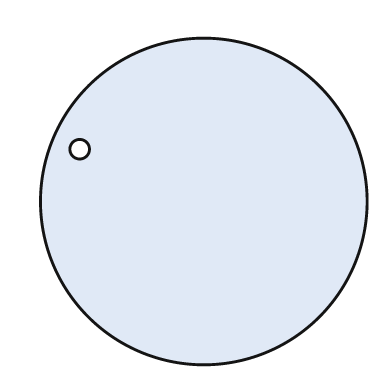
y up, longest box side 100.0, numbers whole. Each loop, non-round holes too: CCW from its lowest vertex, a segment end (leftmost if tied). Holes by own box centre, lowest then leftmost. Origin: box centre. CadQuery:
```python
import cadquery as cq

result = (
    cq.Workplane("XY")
    .moveTo(0.0, 0.0)
    .circle(50.0)
    .moveTo(-38.0, 16.0)
    .circle(3.0)
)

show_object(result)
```